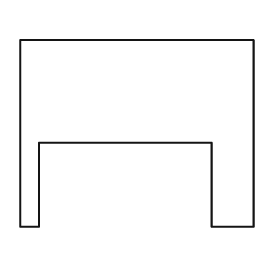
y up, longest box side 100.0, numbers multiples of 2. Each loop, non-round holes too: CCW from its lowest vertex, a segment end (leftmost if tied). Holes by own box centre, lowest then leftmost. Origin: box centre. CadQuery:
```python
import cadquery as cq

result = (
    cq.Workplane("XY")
    .moveTo(-50.0, -40.0)
    .lineTo(-42.0, -40.0)
    .lineTo(-42.0, -4.0)
    .lineTo(32.0, -4.0)
    .lineTo(32.0, -40.0)
    .lineTo(50.0, -40.0)
    .lineTo(50.0, 40.0)
    .lineTo(-50.0, 40.0)
    .close()
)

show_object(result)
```